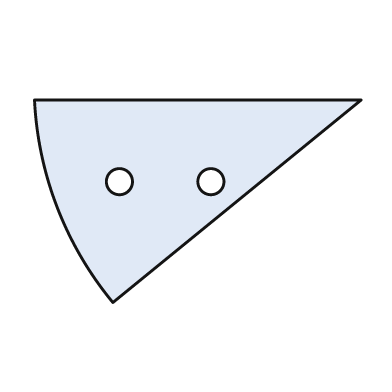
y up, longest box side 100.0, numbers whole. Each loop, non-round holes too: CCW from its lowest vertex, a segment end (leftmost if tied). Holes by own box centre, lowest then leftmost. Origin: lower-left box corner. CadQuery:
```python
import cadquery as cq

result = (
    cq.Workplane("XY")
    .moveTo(24.0, 0.0)
    .lineTo(100.0, 62.0)
    .lineTo(0.0, 62.0)
    .threePointArc((7.0, 29.0), (24.0, 0.0))
    .close()
    .moveTo(26.0, 37.0)
    .circle(4.0)
    .moveTo(54.0, 37.0)
    .circle(4.0)
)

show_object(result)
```